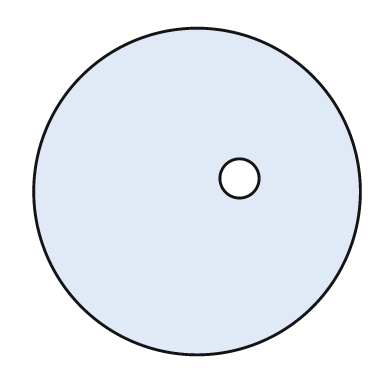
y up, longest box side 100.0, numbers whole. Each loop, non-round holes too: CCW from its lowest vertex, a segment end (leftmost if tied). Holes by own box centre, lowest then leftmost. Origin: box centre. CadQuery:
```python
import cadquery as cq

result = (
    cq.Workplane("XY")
    .moveTo(0.0, 0.0)
    .circle(50.0)
    .moveTo(13.0, 4.0)
    .circle(6.0)
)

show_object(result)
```